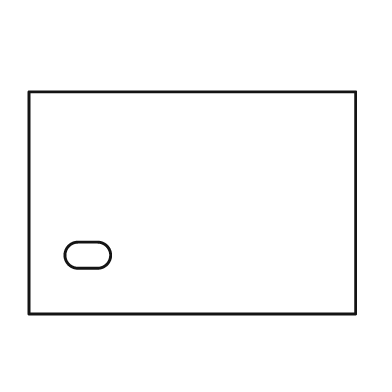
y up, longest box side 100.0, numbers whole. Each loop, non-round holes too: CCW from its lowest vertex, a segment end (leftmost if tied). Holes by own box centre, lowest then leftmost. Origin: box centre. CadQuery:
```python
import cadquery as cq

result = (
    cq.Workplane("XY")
    .moveTo(-50.0, -34.0)
    .lineTo(50.0, -34.0)
    .lineTo(50.0, 34.0)
    .lineTo(-50.0, 34.0)
    .close()
    .moveTo(-35.0, -20.0)
    .lineTo(-29.0, -20.0)
    .threePointArc((-25.0, -16.0), (-29.0, -12.0))
    .lineTo(-35.0, -12.0)
    .threePointArc((-39.0, -16.0), (-35.0, -20.0))
    .close()
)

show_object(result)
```